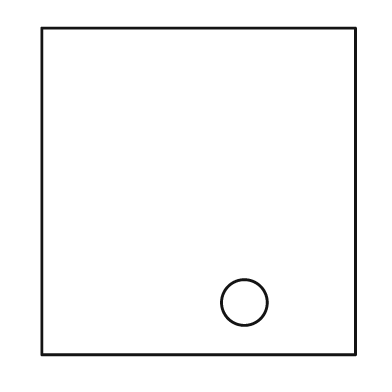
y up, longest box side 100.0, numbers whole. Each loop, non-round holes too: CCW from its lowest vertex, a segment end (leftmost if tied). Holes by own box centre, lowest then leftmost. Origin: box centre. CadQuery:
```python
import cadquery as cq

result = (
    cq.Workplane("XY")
    .moveTo(-48.0, -50.0)
    .lineTo(48.0, -50.0)
    .lineTo(48.0, 50.0)
    .lineTo(-48.0, 50.0)
    .close()
    .moveTo(14.0, -34.0)
    .circle(7.0)
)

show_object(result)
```